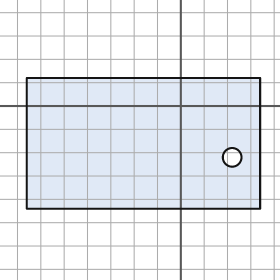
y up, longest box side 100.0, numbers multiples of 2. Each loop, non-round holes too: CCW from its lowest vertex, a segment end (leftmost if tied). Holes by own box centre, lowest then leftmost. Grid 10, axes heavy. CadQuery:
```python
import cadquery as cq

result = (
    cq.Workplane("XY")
    .moveTo(-66.0, -44.0)
    .lineTo(34.0, -44.0)
    .lineTo(34.0, 12.0)
    .lineTo(-66.0, 12.0)
    .close()
    .moveTo(22.0, -22.0)
    .circle(4.0)
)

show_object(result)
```